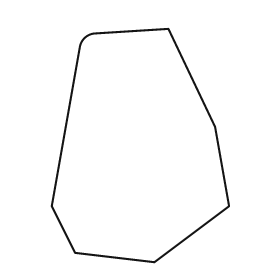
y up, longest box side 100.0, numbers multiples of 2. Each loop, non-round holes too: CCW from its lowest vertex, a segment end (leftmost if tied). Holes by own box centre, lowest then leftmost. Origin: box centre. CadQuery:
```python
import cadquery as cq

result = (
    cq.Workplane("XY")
    .moveTo(6.0, -50.0)
    .lineTo(38.0, -26.0)
    .lineTo(32.0, 8.0)
    .lineTo(12.0, 50.0)
    .lineTo(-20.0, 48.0)
    .threePointArc((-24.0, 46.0), (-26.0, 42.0))
    .lineTo(-38.0, -26.0)
    .lineTo(-28.0, -46.0)
    .close()
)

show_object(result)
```